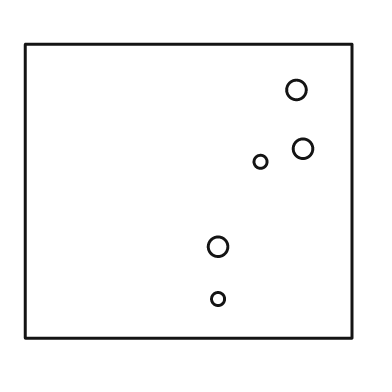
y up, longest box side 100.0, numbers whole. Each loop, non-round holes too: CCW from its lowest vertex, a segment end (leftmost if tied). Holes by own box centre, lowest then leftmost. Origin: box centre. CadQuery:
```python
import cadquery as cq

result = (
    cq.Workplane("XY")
    .moveTo(-50.0, -45.0)
    .lineTo(50.0, -45.0)
    .lineTo(50.0, 45.0)
    .lineTo(-50.0, 45.0)
    .close()
    .moveTo(9.0, -33.0)
    .circle(2.0)
    .moveTo(9.0, -17.0)
    .circle(3.0)
    .moveTo(22.0, 9.0)
    .circle(2.0)
    .moveTo(35.0, 13.0)
    .circle(3.0)
    .moveTo(33.0, 31.0)
    .circle(3.0)
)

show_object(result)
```